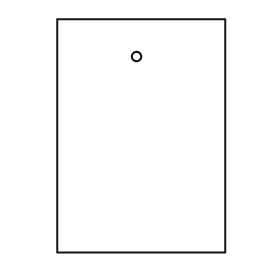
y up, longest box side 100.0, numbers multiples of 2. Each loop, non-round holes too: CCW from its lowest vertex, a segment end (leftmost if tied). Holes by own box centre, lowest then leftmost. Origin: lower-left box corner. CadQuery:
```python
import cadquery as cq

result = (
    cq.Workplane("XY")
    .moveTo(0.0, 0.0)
    .lineTo(72.0, 0.0)
    .lineTo(72.0, 100.0)
    .lineTo(0.0, 100.0)
    .close()
    .moveTo(34.0, 84.0)
    .circle(2.0)
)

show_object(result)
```